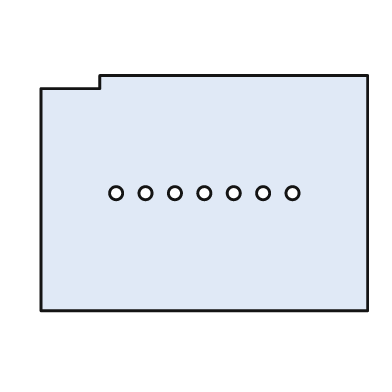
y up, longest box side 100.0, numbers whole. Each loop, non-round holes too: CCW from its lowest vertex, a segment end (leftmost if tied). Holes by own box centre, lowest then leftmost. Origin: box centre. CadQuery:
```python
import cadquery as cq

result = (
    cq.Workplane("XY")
    .moveTo(-50.0, -36.0)
    .lineTo(50.0, -36.0)
    .lineTo(50.0, 36.0)
    .lineTo(-32.0, 36.0)
    .lineTo(-32.0, 32.0)
    .lineTo(-50.0, 32.0)
    .close()
    .moveTo(-27.0, 0.0)
    .circle(2.0)
    .moveTo(-18.0, 0.0)
    .circle(2.0)
    .moveTo(-9.0, 0.0)
    .circle(2.0)
    .moveTo(0.0, 0.0)
    .circle(2.0)
    .moveTo(9.0, 0.0)
    .circle(2.0)
    .moveTo(18.0, 0.0)
    .circle(2.0)
    .moveTo(27.0, 0.0)
    .circle(2.0)
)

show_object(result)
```